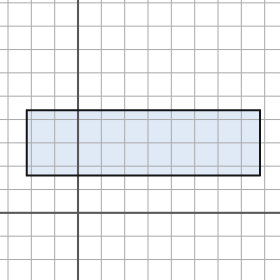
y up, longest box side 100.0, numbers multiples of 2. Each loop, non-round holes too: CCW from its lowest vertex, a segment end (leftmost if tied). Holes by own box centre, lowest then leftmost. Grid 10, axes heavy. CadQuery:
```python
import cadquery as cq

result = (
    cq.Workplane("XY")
    .moveTo(-22.0, 16.0)
    .lineTo(78.0, 16.0)
    .lineTo(78.0, 44.0)
    .lineTo(-22.0, 44.0)
    .close()
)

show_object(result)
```